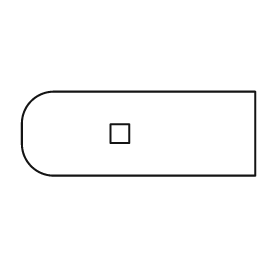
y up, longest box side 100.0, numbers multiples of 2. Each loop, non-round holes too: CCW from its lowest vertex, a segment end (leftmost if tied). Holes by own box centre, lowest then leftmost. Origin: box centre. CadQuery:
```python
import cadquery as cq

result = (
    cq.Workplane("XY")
    .moveTo(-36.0, -18.0)
    .lineTo(50.0, -18.0)
    .lineTo(50.0, 18.0)
    .lineTo(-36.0, 18.0)
    .threePointArc((-46.0, 14.0), (-50.0, 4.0))
    .lineTo(-50.0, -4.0)
    .threePointArc((-46.0, -14.0), (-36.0, -18.0))
    .close()
    .moveTo(-12.0, -4.0)
    .lineTo(-4.0, -4.0)
    .lineTo(-4.0, 4.0)
    .lineTo(-12.0, 4.0)
    .close()
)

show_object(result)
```